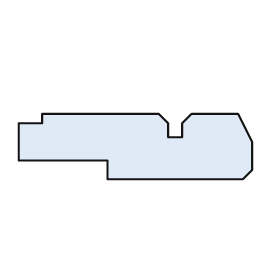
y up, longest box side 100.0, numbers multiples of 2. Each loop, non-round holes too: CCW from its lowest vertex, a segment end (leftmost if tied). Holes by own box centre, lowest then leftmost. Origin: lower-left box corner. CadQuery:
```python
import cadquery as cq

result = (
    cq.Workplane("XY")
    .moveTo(38.0, 0.0)
    .lineTo(96.0, 0.0)
    .lineTo(100.0, 4.0)
    .lineTo(100.0, 16.0)
    .lineTo(94.0, 28.0)
    .lineTo(74.0, 28.0)
    .lineTo(70.0, 24.0)
    .lineTo(70.0, 18.0)
    .lineTo(64.0, 18.0)
    .lineTo(64.0, 24.0)
    .lineTo(60.0, 28.0)
    .lineTo(10.0, 28.0)
    .lineTo(10.0, 24.0)
    .lineTo(0.0, 24.0)
    .lineTo(0.0, 8.0)
    .lineTo(38.0, 8.0)
    .close()
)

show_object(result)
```